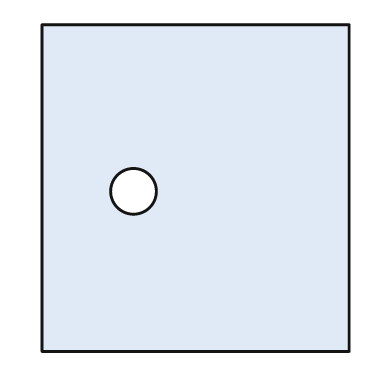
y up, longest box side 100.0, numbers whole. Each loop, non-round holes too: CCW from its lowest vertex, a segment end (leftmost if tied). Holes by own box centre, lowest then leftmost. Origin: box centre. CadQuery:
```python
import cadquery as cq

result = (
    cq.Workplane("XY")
    .moveTo(-47.0, -50.0)
    .lineTo(47.0, -50.0)
    .lineTo(47.0, 50.0)
    .lineTo(-47.0, 50.0)
    .close()
    .moveTo(-19.0, -1.0)
    .circle(7.0)
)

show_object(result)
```